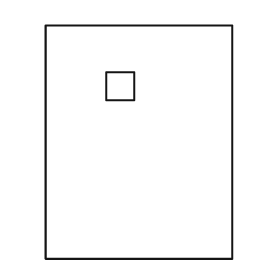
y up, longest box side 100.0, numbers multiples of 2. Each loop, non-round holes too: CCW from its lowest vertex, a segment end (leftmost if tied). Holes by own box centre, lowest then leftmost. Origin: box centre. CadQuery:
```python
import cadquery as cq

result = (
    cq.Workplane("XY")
    .moveTo(-40.0, -50.0)
    .lineTo(40.0, -50.0)
    .lineTo(40.0, 50.0)
    .lineTo(-40.0, 50.0)
    .close()
    .moveTo(-14.0, 18.0)
    .lineTo(-2.0, 18.0)
    .lineTo(-2.0, 30.0)
    .lineTo(-14.0, 30.0)
    .close()
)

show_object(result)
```